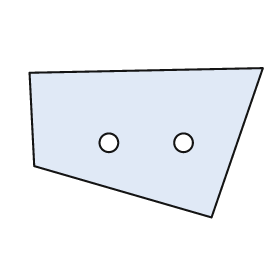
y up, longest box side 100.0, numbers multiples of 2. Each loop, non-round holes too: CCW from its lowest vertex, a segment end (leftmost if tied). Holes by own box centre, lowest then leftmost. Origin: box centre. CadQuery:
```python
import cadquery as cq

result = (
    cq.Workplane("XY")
    .moveTo(28.0, -32.0)
    .lineTo(50.0, 32.0)
    .lineTo(-50.0, 30.0)
    .lineTo(-48.0, -10.0)
    .close()
    .moveTo(-16.0, 0.0)
    .circle(4.0)
    .moveTo(16.0, 0.0)
    .circle(4.0)
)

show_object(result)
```